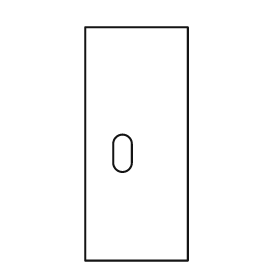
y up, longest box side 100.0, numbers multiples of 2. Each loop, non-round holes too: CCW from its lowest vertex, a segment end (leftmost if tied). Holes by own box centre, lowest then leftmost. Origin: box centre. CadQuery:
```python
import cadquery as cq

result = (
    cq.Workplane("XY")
    .moveTo(-22.0, -50.0)
    .lineTo(22.0, -50.0)
    .lineTo(22.0, 50.0)
    .lineTo(-22.0, 50.0)
    .close()
    .moveTo(-10.0, -8.0)
    .threePointArc((-6.0, -12.0), (-2.0, -8.0))
    .lineTo(-2.0, 0.0)
    .threePointArc((-6.0, 4.0), (-10.0, 0.0))
    .close()
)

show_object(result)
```